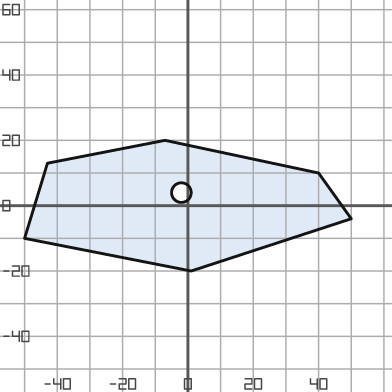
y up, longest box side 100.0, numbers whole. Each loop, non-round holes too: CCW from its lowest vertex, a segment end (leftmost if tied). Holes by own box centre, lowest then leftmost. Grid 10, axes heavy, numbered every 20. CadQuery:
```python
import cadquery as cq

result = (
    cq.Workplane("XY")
    .moveTo(1.0, -20.0)
    .lineTo(50.0, -4.0)
    .lineTo(40.0, 10.0)
    .lineTo(-7.0, 20.0)
    .lineTo(-43.0, 13.0)
    .lineTo(-50.0, -10.0)
    .close()
    .moveTo(-2.0, 4.0)
    .circle(3.0)
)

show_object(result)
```